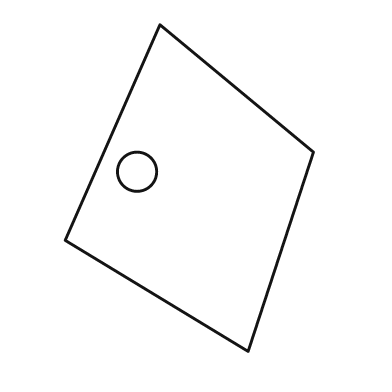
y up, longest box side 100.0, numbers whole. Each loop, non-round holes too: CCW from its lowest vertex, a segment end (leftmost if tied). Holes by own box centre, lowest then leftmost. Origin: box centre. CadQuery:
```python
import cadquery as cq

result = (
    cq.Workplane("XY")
    .moveTo(18.0, -50.0)
    .lineTo(38.0, 11.0)
    .lineTo(-9.0, 50.0)
    .lineTo(-38.0, -16.0)
    .close()
    .moveTo(-16.0, 5.0)
    .circle(6.0)
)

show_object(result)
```